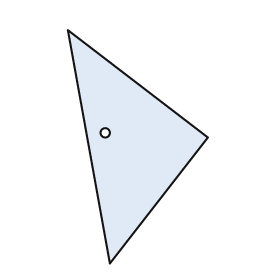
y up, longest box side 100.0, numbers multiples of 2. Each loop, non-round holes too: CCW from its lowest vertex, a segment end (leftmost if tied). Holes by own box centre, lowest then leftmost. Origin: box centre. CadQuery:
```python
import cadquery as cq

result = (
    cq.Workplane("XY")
    .moveTo(-12.0, -50.0)
    .lineTo(30.0, 4.0)
    .lineTo(-30.0, 50.0)
    .close()
    .moveTo(-14.0, 6.0)
    .circle(2.0)
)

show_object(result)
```